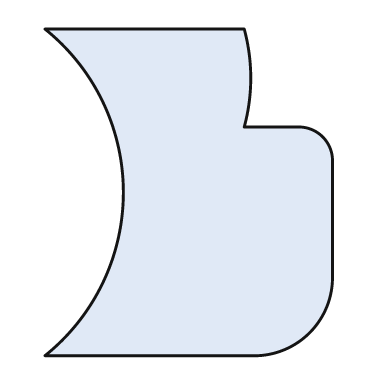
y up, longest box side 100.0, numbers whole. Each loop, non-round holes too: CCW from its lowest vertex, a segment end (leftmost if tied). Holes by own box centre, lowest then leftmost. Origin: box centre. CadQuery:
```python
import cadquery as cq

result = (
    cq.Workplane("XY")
    .moveTo(-44.0, -50.0)
    .lineTo(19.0, -50.0)
    .threePointArc((37.0, -43.0), (44.0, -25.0))
    .lineTo(44.0, 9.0)
    .threePointArc((41.0, 17.0), (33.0, 20.0))
    .lineTo(17.0, 20.0)
    .threePointArc((19.0, 35.0), (17.0, 50.0))
    .lineTo(-44.0, 50.0)
    .threePointArc((-20.0, 0.0), (-44.0, -50.0))
    .close()
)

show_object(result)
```